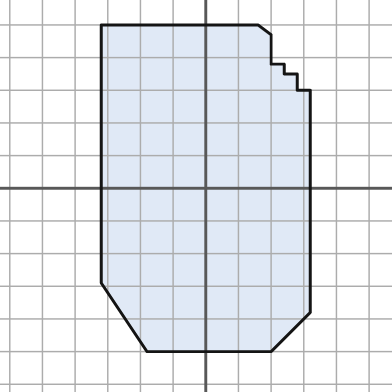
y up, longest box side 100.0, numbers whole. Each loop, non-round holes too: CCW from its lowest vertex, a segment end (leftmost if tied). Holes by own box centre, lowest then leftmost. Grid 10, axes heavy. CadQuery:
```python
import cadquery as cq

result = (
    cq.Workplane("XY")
    .moveTo(-18.0, -50.0)
    .lineTo(20.0, -50.0)
    .lineTo(32.0, -38.0)
    .lineTo(32.0, 30.0)
    .lineTo(28.0, 30.0)
    .lineTo(28.0, 35.0)
    .lineTo(24.0, 35.0)
    .lineTo(24.0, 38.0)
    .lineTo(20.0, 38.0)
    .lineTo(20.0, 47.0)
    .lineTo(16.0, 50.0)
    .lineTo(-32.0, 50.0)
    .lineTo(-32.0, -29.0)
    .close()
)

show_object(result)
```